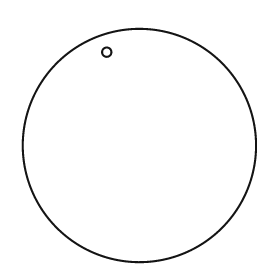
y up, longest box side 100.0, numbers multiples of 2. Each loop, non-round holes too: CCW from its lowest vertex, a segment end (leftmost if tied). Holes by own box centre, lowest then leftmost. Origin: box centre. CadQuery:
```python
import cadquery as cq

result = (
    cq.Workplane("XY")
    .moveTo(0.0, 0.0)
    .circle(50.0)
    .moveTo(-14.0, 40.0)
    .circle(2.0)
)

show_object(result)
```